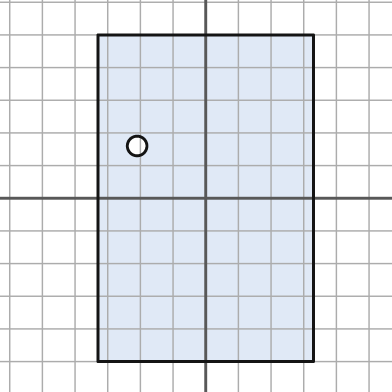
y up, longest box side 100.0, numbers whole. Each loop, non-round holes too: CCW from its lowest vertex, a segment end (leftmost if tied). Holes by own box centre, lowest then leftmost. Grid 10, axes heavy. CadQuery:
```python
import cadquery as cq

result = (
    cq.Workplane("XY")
    .moveTo(-33.0, -50.0)
    .lineTo(33.0, -50.0)
    .lineTo(33.0, 50.0)
    .lineTo(-33.0, 50.0)
    .close()
    .moveTo(-21.0, 16.0)
    .circle(3.0)
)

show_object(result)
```